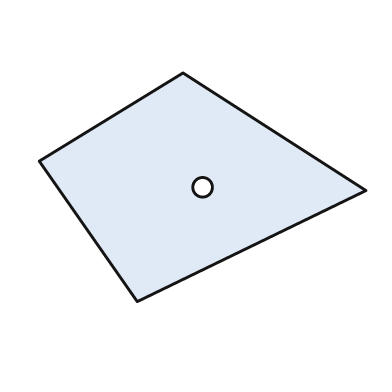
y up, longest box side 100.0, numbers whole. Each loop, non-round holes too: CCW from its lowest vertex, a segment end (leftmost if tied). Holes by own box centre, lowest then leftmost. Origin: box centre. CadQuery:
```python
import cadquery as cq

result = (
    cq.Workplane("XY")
    .moveTo(-20.0, -35.0)
    .lineTo(50.0, -1.0)
    .lineTo(-6.0, 35.0)
    .lineTo(-50.0, 8.0)
    .close()
    .moveTo(0.0, 0.0)
    .circle(3.0)
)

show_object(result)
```